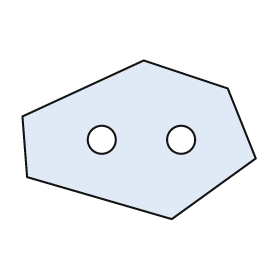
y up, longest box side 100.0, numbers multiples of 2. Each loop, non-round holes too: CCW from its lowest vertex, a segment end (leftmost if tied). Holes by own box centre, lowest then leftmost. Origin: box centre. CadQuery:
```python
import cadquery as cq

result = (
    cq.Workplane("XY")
    .moveTo(14.0, -34.0)
    .lineTo(50.0, -8.0)
    .lineTo(38.0, 22.0)
    .lineTo(2.0, 34.0)
    .lineTo(-50.0, 10.0)
    .lineTo(-48.0, -16.0)
    .close()
    .moveTo(-16.0, 0.0)
    .circle(6.0)
    .moveTo(18.0, 0.0)
    .circle(6.0)
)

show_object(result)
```